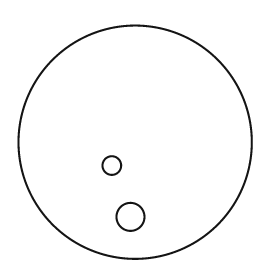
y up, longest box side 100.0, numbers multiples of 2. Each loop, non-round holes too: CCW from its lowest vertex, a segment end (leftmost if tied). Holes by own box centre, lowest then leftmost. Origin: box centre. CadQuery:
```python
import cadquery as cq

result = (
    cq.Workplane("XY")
    .moveTo(0.0, 0.0)
    .circle(50.0)
    .moveTo(-2.0, -32.0)
    .circle(6.0)
    .moveTo(-10.0, -10.0)
    .circle(4.0)
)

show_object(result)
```